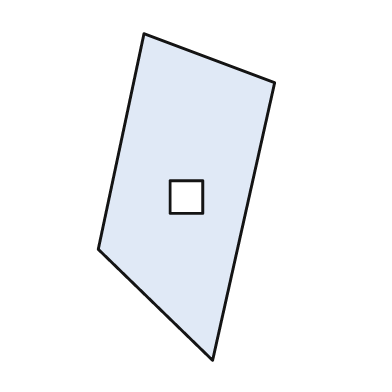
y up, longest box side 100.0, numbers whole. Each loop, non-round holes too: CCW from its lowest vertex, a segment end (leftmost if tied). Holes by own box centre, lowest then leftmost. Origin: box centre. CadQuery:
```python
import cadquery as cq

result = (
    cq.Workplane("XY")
    .moveTo(8.0, -50.0)
    .lineTo(27.0, 35.0)
    .lineTo(-13.0, 50.0)
    .lineTo(-27.0, -16.0)
    .close()
    .moveTo(-5.0, -5.0)
    .lineTo(5.0, -5.0)
    .lineTo(5.0, 5.0)
    .lineTo(-5.0, 5.0)
    .close()
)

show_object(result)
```